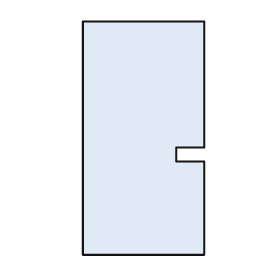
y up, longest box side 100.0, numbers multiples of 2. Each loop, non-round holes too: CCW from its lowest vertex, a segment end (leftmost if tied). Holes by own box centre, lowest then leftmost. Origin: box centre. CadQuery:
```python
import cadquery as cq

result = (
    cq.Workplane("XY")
    .moveTo(-26.0, -50.0)
    .lineTo(26.0, -50.0)
    .lineTo(26.0, -10.0)
    .lineTo(14.0, -10.0)
    .lineTo(14.0, -4.0)
    .lineTo(26.0, -4.0)
    .lineTo(26.0, 50.0)
    .lineTo(-26.0, 50.0)
    .close()
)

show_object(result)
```